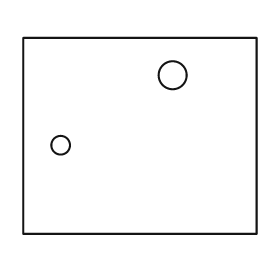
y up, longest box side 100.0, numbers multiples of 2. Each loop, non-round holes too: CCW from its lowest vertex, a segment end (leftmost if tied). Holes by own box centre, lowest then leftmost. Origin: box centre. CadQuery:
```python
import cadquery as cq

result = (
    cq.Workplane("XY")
    .moveTo(-50.0, -42.0)
    .lineTo(50.0, -42.0)
    .lineTo(50.0, 42.0)
    .lineTo(-50.0, 42.0)
    .close()
    .moveTo(-34.0, -4.0)
    .circle(4.0)
    .moveTo(14.0, 26.0)
    .circle(6.0)
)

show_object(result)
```